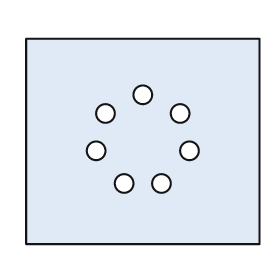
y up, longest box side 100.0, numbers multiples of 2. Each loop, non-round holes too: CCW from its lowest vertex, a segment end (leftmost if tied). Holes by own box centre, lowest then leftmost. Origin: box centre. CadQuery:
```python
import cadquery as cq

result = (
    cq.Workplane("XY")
    .moveTo(-50.0, -44.0)
    .lineTo(50.0, -44.0)
    .lineTo(50.0, 44.0)
    .lineTo(-50.0, 44.0)
    .close()
    .moveTo(-8.0, -18.0)
    .circle(4.0)
    .moveTo(8.0, -18.0)
    .circle(4.0)
    .moveTo(-20.0, -4.0)
    .circle(4.0)
    .moveTo(20.0, -4.0)
    .circle(4.0)
    .moveTo(-16.0, 12.0)
    .circle(4.0)
    .moveTo(16.0, 12.0)
    .circle(4.0)
    .moveTo(0.0, 20.0)
    .circle(4.0)
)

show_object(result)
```